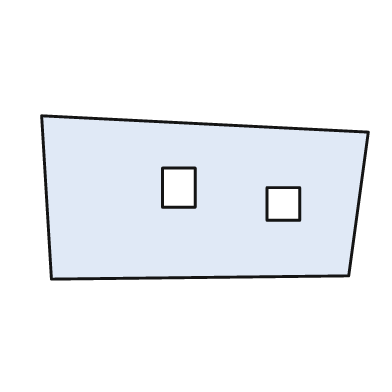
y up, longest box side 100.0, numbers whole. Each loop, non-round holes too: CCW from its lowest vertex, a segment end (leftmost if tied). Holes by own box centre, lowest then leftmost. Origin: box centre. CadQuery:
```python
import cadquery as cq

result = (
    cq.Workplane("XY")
    .moveTo(-47.0, -25.0)
    .lineTo(44.0, -24.0)
    .lineTo(50.0, 20.0)
    .lineTo(-50.0, 25.0)
    .close()
    .moveTo(19.0, -7.0)
    .lineTo(29.0, -7.0)
    .lineTo(29.0, 3.0)
    .lineTo(19.0, 3.0)
    .close()
    .moveTo(-13.0, -3.0)
    .lineTo(-3.0, -3.0)
    .lineTo(-3.0, 9.0)
    .lineTo(-13.0, 9.0)
    .close()
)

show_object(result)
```